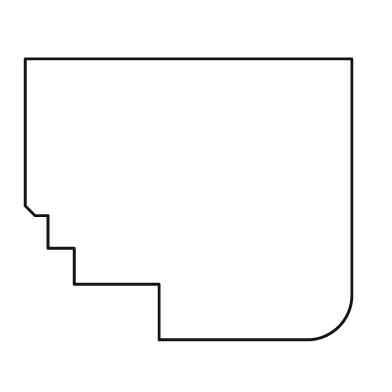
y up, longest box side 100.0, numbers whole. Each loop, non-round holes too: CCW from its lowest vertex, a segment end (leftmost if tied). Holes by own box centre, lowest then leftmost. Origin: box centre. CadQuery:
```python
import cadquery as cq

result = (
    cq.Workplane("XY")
    .moveTo(-9.0, -43.0)
    .lineTo(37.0, -43.0)
    .threePointArc((46.0, -39.0), (50.0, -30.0))
    .lineTo(50.0, 43.0)
    .lineTo(-50.0, 43.0)
    .lineTo(-50.0, -2.0)
    .lineTo(-47.0, -5.0)
    .lineTo(-43.0, -5.0)
    .lineTo(-43.0, -15.0)
    .lineTo(-35.0, -15.0)
    .lineTo(-35.0, -26.0)
    .lineTo(-9.0, -26.0)
    .close()
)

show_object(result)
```